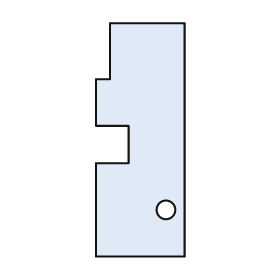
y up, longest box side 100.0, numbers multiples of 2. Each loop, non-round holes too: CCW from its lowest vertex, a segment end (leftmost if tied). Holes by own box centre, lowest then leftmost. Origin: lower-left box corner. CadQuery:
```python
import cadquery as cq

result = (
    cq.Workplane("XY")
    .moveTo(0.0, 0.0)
    .lineTo(38.0, 0.0)
    .lineTo(38.0, 100.0)
    .lineTo(6.0, 100.0)
    .lineTo(6.0, 76.0)
    .lineTo(0.0, 76.0)
    .lineTo(0.0, 56.0)
    .lineTo(14.0, 56.0)
    .lineTo(14.0, 40.0)
    .lineTo(0.0, 40.0)
    .close()
    .moveTo(30.0, 20.0)
    .circle(4.0)
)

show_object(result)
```